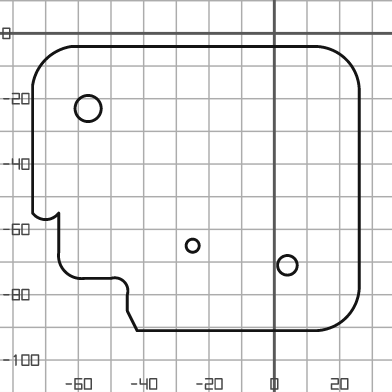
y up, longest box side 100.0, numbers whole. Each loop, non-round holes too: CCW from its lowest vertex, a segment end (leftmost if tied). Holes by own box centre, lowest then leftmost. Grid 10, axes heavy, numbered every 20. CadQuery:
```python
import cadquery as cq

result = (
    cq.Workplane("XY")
    .moveTo(-42.0, -91.0)
    .lineTo(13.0, -91.0)
    .threePointArc((22.0, -87.0), (26.0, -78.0))
    .lineTo(26.0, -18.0)
    .threePointArc((22.0, -8.0), (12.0, -4.0))
    .lineTo(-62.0, -4.0)
    .threePointArc((-70.0, -8.0), (-74.0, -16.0))
    .lineTo(-74.0, -55.0)
    .threePointArc((-70.0, -57.0), (-66.0, -55.0))
    .lineTo(-66.0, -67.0)
    .threePointArc((-64.0, -73.0), (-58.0, -75.0))
    .lineTo(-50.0, -75.0)
    .threePointArc((-46.0, -76.0), (-45.0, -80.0))
    .lineTo(-45.0, -85.0)
    .close()
    .moveTo(4.0, -71.0)
    .circle(3.0)
    .moveTo(-25.0, -65.0)
    .circle(2.0)
    .moveTo(-57.0, -23.0)
    .circle(4.0)
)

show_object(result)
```